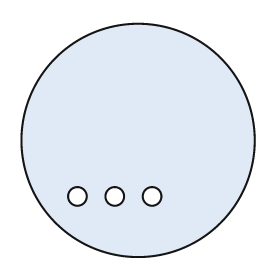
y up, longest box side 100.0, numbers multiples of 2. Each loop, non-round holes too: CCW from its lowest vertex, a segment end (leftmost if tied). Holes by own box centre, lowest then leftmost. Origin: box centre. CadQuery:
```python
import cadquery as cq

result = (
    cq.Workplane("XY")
    .moveTo(0.0, 0.0)
    .circle(50.0)
    .moveTo(-26.0, -24.0)
    .circle(4.0)
    .moveTo(-10.0, -24.0)
    .circle(4.0)
    .moveTo(6.0, -24.0)
    .circle(4.0)
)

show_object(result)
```